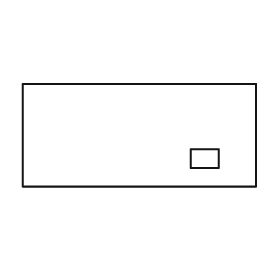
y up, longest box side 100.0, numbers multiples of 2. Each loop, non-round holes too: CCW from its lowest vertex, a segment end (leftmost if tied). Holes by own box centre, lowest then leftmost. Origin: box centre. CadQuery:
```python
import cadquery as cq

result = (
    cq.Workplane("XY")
    .moveTo(-50.0, -22.0)
    .lineTo(50.0, -22.0)
    .lineTo(50.0, 22.0)
    .lineTo(-50.0, 22.0)
    .close()
    .moveTo(22.0, -14.0)
    .lineTo(34.0, -14.0)
    .lineTo(34.0, -6.0)
    .lineTo(22.0, -6.0)
    .close()
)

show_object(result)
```